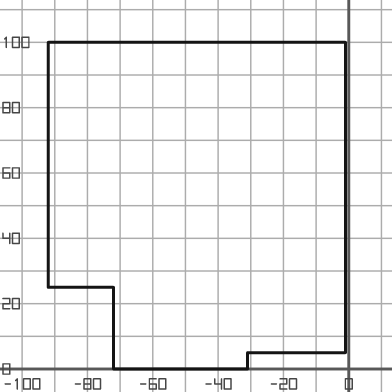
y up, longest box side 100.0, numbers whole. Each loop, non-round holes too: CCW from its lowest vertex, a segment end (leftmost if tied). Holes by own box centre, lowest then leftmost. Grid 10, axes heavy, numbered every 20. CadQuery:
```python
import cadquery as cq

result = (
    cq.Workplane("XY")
    .moveTo(-72.0, 0.0)
    .lineTo(-31.0, 0.0)
    .lineTo(-31.0, 5.0)
    .lineTo(-1.0, 5.0)
    .lineTo(-1.0, 100.0)
    .lineTo(-92.0, 100.0)
    .lineTo(-92.0, 25.0)
    .lineTo(-72.0, 25.0)
    .close()
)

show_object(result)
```